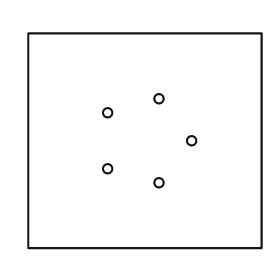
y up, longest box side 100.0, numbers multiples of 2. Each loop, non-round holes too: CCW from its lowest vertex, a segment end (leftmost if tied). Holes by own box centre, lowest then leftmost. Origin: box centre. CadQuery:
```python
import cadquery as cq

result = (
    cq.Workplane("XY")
    .moveTo(-50.0, -46.0)
    .lineTo(50.0, -46.0)
    .lineTo(50.0, 46.0)
    .lineTo(-50.0, 46.0)
    .close()
    .moveTo(6.0, -18.0)
    .circle(2.0)
    .moveTo(-16.0, -12.0)
    .circle(2.0)
    .moveTo(20.0, 0.0)
    .circle(2.0)
    .moveTo(-16.0, 12.0)
    .circle(2.0)
    .moveTo(6.0, 18.0)
    .circle(2.0)
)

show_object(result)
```